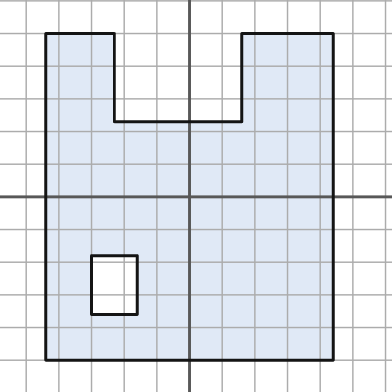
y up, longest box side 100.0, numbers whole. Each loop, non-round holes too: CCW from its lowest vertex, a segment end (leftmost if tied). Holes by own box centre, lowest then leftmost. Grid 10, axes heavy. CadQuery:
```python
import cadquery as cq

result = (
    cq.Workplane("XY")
    .moveTo(-44.0, -50.0)
    .lineTo(44.0, -50.0)
    .lineTo(44.0, 50.0)
    .lineTo(16.0, 50.0)
    .lineTo(16.0, 23.0)
    .lineTo(-23.0, 23.0)
    .lineTo(-23.0, 50.0)
    .lineTo(-44.0, 50.0)
    .close()
    .moveTo(-30.0, -36.0)
    .lineTo(-16.0, -36.0)
    .lineTo(-16.0, -18.0)
    .lineTo(-30.0, -18.0)
    .close()
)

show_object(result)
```